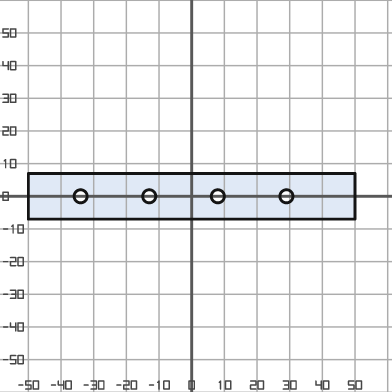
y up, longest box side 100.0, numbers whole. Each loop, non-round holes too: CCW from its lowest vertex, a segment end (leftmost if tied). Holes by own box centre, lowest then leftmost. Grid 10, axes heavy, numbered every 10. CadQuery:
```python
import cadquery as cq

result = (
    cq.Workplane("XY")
    .moveTo(-50.0, -7.0)
    .lineTo(50.0, -7.0)
    .lineTo(50.0, 7.0)
    .lineTo(-50.0, 7.0)
    .close()
    .moveTo(-34.0, 0.0)
    .circle(2.0)
    .moveTo(-13.0, 0.0)
    .circle(2.0)
    .moveTo(8.0, 0.0)
    .circle(2.0)
    .moveTo(29.0, 0.0)
    .circle(2.0)
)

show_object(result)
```